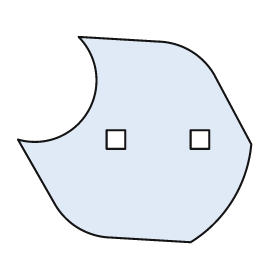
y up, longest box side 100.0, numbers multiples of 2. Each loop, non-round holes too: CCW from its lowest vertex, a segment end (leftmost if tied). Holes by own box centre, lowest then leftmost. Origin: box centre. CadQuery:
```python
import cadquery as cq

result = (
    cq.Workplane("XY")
    .moveTo(24.0, -44.0)
    .threePointArc((42.0, -26.0), (50.0, -2.0))
    .lineTo(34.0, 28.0)
    .threePointArc((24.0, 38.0), (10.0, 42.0))
    .lineTo(-24.0, 44.0)
    .threePointArc((-20.0, 12.0), (-50.0, 0.0))
    .lineTo(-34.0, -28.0)
    .threePointArc((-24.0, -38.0), (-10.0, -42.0))
    .close()
    .moveTo(-12.0, -4.0)
    .lineTo(-4.0, -4.0)
    .lineTo(-4.0, 4.0)
    .lineTo(-12.0, 4.0)
    .close()
    .moveTo(24.0, -4.0)
    .lineTo(32.0, -4.0)
    .lineTo(32.0, 4.0)
    .lineTo(24.0, 4.0)
    .close()
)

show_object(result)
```